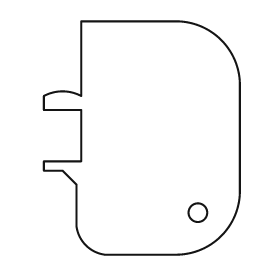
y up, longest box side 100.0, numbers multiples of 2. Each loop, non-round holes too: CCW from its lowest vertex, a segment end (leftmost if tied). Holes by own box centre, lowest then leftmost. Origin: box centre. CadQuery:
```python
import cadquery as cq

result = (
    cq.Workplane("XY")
    .moveTo(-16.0, -50.0)
    .lineTo(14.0, -50.0)
    .threePointArc((34.0, -42.0), (42.0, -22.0))
    .lineTo(42.0, 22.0)
    .threePointArc((34.0, 42.0), (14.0, 50.0))
    .lineTo(-26.0, 50.0)
    .lineTo(-26.0, 18.0)
    .threePointArc((-34.0, 20.0), (-42.0, 18.0))
    .lineTo(-42.0, 12.0)
    .lineTo(-26.0, 12.0)
    .lineTo(-26.0, -10.0)
    .lineTo(-42.0, -10.0)
    .lineTo(-42.0, -14.0)
    .lineTo(-34.0, -14.0)
    .lineTo(-28.0, -20.0)
    .lineTo(-28.0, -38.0)
    .threePointArc((-24.0, -46.0), (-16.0, -50.0))
    .close()
    .moveTo(24.0, -32.0)
    .circle(4.0)
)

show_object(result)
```